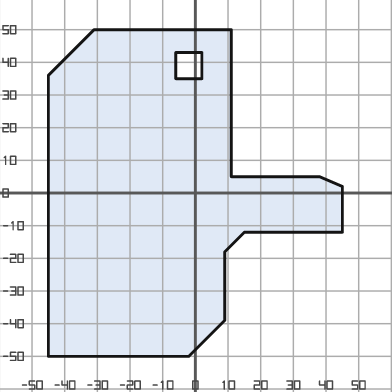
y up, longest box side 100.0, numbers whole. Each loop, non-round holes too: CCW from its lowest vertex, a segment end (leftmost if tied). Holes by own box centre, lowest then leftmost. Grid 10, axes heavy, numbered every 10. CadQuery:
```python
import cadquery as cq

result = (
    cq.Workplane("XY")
    .moveTo(-45.0, -50.0)
    .lineTo(-2.0, -50.0)
    .lineTo(9.0, -39.0)
    .lineTo(9.0, -18.0)
    .lineTo(15.0, -12.0)
    .lineTo(45.0, -12.0)
    .lineTo(45.0, 2.0)
    .lineTo(38.0, 5.0)
    .lineTo(11.0, 5.0)
    .lineTo(11.0, 50.0)
    .lineTo(-31.0, 50.0)
    .lineTo(-45.0, 36.0)
    .close()
    .moveTo(-6.0, 35.0)
    .lineTo(2.0, 35.0)
    .lineTo(2.0, 43.0)
    .lineTo(-6.0, 43.0)
    .close()
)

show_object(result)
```